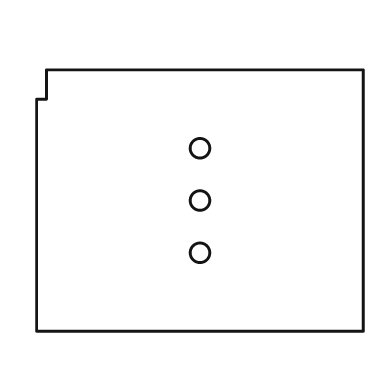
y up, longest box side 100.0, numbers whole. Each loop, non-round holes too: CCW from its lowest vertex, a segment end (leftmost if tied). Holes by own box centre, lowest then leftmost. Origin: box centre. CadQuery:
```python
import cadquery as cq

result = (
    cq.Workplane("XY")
    .moveTo(-50.0, -40.0)
    .lineTo(50.0, -40.0)
    .lineTo(50.0, 40.0)
    .lineTo(-47.0, 40.0)
    .lineTo(-47.0, 31.0)
    .lineTo(-50.0, 31.0)
    .close()
    .moveTo(0.0, -16.0)
    .circle(3.0)
    .moveTo(0.0, 0.0)
    .circle(3.0)
    .moveTo(0.0, 16.0)
    .circle(3.0)
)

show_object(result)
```